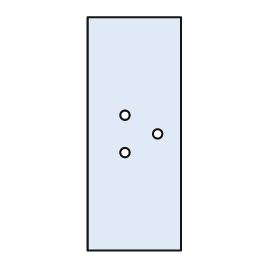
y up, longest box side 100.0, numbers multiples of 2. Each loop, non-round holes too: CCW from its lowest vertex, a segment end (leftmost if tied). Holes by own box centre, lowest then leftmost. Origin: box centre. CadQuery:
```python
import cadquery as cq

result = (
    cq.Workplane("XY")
    .moveTo(-20.0, -50.0)
    .lineTo(20.0, -50.0)
    .lineTo(20.0, 50.0)
    .lineTo(-20.0, 50.0)
    .close()
    .moveTo(-4.0, -8.0)
    .circle(2.0)
    .moveTo(10.0, 0.0)
    .circle(2.0)
    .moveTo(-4.0, 8.0)
    .circle(2.0)
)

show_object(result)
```